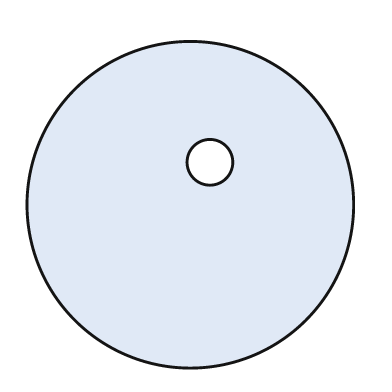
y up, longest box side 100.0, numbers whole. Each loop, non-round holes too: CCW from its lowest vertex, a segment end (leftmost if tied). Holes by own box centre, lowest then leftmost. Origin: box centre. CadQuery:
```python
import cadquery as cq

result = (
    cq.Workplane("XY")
    .moveTo(0.0, 0.0)
    .circle(50.0)
    .moveTo(6.0, 13.0)
    .circle(7.0)
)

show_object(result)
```